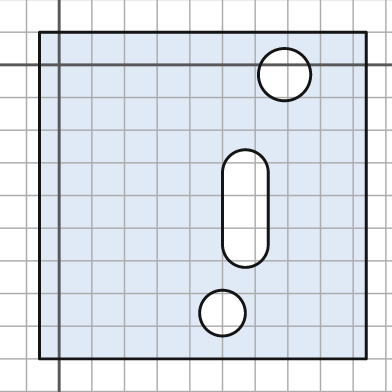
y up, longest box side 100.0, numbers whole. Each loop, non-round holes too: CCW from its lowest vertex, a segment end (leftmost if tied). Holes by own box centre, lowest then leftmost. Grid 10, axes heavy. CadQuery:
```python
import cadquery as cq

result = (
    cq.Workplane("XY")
    .moveTo(-6.0, -90.0)
    .lineTo(94.0, -90.0)
    .lineTo(94.0, 10.0)
    .lineTo(-6.0, 10.0)
    .close()
    .moveTo(50.0, -76.0)
    .circle(7.0)
    .moveTo(50.0, -55.0)
    .threePointArc((57.0, -62.0), (64.0, -55.0))
    .lineTo(64.0, -33.0)
    .threePointArc((57.0, -26.0), (50.0, -33.0))
    .close()
    .moveTo(69.0, -3.0)
    .circle(8.0)
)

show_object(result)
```